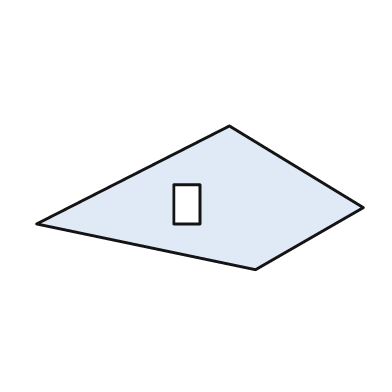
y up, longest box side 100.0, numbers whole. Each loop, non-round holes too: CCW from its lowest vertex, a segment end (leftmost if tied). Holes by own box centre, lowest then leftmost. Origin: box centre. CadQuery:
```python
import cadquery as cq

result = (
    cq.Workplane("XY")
    .moveTo(17.0, -22.0)
    .lineTo(50.0, -3.0)
    .lineTo(9.0, 22.0)
    .lineTo(-50.0, -8.0)
    .close()
    .moveTo(-8.0, -8.0)
    .lineTo(0.0, -8.0)
    .lineTo(0.0, 4.0)
    .lineTo(-8.0, 4.0)
    .close()
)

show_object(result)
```